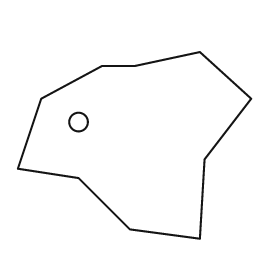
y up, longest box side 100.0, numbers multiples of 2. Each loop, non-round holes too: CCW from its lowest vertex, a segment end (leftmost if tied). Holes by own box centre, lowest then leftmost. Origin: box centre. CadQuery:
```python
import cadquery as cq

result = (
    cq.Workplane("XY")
    .moveTo(28.0, -40.0)
    .lineTo(30.0, -6.0)
    .lineTo(50.0, 20.0)
    .lineTo(28.0, 40.0)
    .lineTo(0.0, 34.0)
    .lineTo(-14.0, 34.0)
    .lineTo(-40.0, 20.0)
    .lineTo(-50.0, -10.0)
    .lineTo(-24.0, -14.0)
    .lineTo(-2.0, -36.0)
    .close()
    .moveTo(-24.0, 10.0)
    .circle(4.0)
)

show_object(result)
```